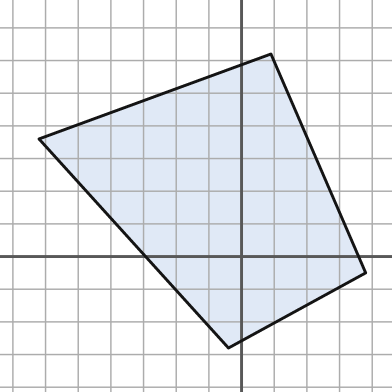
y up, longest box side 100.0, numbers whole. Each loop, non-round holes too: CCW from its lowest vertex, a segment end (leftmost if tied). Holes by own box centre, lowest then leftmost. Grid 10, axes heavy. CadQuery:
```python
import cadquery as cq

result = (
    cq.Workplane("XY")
    .moveTo(-4.0, -28.0)
    .lineTo(38.0, -5.0)
    .lineTo(9.0, 62.0)
    .lineTo(-62.0, 36.0)
    .close()
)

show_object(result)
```